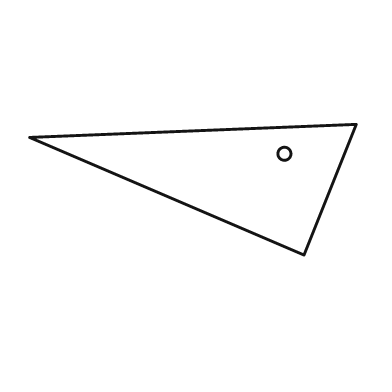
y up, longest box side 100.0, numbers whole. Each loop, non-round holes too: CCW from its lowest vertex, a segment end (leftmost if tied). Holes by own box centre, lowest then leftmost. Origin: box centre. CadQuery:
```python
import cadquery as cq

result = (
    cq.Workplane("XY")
    .moveTo(34.0, -20.0)
    .lineTo(50.0, 20.0)
    .lineTo(-50.0, 16.0)
    .close()
    .moveTo(28.0, 11.0)
    .circle(2.0)
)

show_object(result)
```